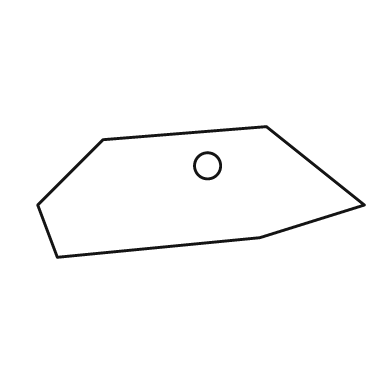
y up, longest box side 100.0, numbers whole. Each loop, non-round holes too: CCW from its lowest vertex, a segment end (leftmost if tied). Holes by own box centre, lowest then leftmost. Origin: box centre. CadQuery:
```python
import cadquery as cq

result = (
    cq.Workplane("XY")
    .moveTo(-44.0, -20.0)
    .lineTo(18.0, -14.0)
    .lineTo(50.0, -4.0)
    .lineTo(20.0, 20.0)
    .lineTo(-30.0, 16.0)
    .lineTo(-50.0, -4.0)
    .close()
    .moveTo(2.0, 8.0)
    .circle(4.0)
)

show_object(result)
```